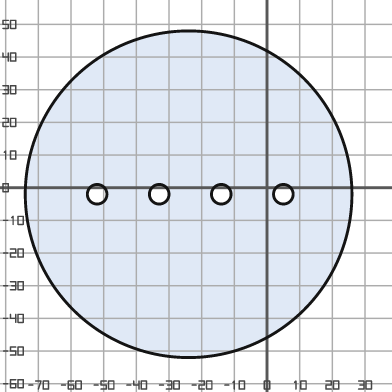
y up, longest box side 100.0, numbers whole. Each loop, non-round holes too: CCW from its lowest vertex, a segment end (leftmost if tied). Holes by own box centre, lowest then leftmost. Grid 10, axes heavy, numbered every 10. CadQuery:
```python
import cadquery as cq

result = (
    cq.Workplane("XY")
    .moveTo(-24.0, -2.0)
    .circle(50.0)
    .moveTo(-52.0, -2.0)
    .circle(3.0)
    .moveTo(-33.0, -2.0)
    .circle(3.0)
    .moveTo(-14.0, -2.0)
    .circle(3.0)
    .moveTo(5.0, -2.0)
    .circle(3.0)
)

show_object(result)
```